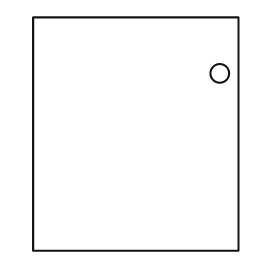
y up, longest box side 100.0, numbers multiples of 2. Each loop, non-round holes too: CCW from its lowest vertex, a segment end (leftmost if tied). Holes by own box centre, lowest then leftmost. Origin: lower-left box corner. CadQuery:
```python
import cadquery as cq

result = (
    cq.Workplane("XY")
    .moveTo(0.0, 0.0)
    .lineTo(88.0, 0.0)
    .lineTo(88.0, 100.0)
    .lineTo(0.0, 100.0)
    .close()
    .moveTo(80.0, 76.0)
    .circle(4.0)
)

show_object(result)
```